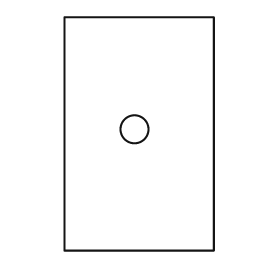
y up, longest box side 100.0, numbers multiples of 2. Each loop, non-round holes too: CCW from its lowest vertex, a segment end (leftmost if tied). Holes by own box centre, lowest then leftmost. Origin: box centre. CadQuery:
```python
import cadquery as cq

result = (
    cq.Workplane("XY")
    .moveTo(-32.0, -50.0)
    .lineTo(32.0, -50.0)
    .lineTo(32.0, 50.0)
    .lineTo(-32.0, 50.0)
    .close()
    .moveTo(-2.0, 2.0)
    .circle(6.0)
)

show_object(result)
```